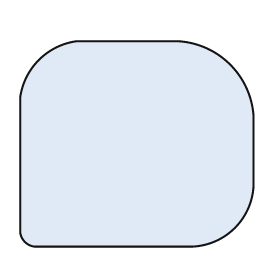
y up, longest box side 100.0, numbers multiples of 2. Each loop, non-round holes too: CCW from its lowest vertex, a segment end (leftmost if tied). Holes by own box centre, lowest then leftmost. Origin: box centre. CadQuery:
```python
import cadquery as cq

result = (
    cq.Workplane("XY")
    .moveTo(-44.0, -44.0)
    .lineTo(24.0, -44.0)
    .threePointArc((42.0, -36.0), (50.0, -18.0))
    .lineTo(50.0, 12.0)
    .threePointArc((40.0, 34.0), (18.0, 44.0))
    .lineTo(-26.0, 44.0)
    .threePointArc((-42.0, 36.0), (-50.0, 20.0))
    .lineTo(-50.0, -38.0)
    .threePointArc((-48.0, -42.0), (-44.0, -44.0))
    .close()
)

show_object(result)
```